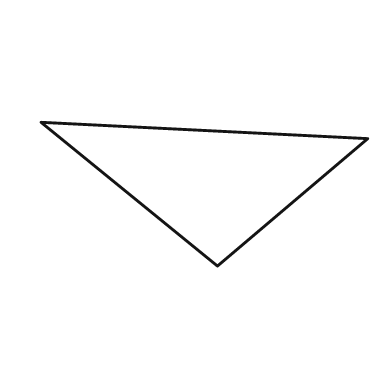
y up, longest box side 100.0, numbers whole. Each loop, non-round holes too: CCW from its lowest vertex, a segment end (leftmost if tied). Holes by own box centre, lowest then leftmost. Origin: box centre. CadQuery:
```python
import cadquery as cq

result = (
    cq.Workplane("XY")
    .moveTo(4.0, -22.0)
    .lineTo(50.0, 17.0)
    .lineTo(-50.0, 22.0)
    .close()
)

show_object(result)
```